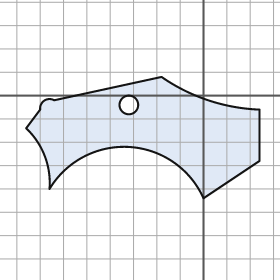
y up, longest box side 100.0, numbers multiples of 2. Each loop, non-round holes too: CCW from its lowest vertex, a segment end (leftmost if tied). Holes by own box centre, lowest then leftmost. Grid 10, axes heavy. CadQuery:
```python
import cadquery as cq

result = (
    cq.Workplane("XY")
    .moveTo(0.0, -44.0)
    .lineTo(24.0, -28.0)
    .lineTo(24.0, -6.0)
    .threePointArc((2.0, -2.0), (-18.0, 8.0))
    .lineTo(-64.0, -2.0)
    .threePointArc((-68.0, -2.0), (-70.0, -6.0))
    .lineTo(-76.0, -14.0)
    .threePointArc((-68.0, -26.0), (-66.0, -40.0))
    .threePointArc((-32.0, -22.0), (0.0, -44.0))
    .close()
    .moveTo(-32.0, -4.0)
    .circle(4.0)
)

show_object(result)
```